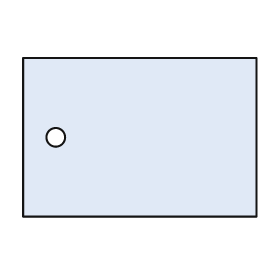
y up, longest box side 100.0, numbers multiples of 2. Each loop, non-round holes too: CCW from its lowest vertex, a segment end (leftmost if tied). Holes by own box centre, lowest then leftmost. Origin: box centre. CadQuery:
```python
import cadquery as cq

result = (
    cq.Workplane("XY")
    .moveTo(-50.0, -34.0)
    .lineTo(50.0, -34.0)
    .lineTo(50.0, 34.0)
    .lineTo(-50.0, 34.0)
    .close()
    .moveTo(-36.0, 0.0)
    .circle(4.0)
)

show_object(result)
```